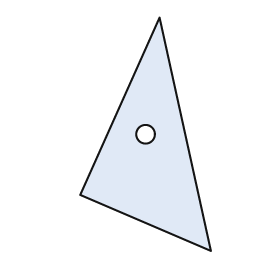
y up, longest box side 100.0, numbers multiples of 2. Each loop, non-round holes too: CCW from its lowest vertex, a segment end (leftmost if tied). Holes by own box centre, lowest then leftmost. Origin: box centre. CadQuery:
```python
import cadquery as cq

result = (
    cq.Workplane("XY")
    .moveTo(28.0, -50.0)
    .lineTo(6.0, 50.0)
    .lineTo(-28.0, -26.0)
    .close()
    .moveTo(0.0, 0.0)
    .circle(4.0)
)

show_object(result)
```